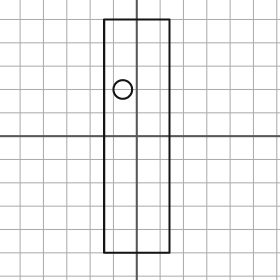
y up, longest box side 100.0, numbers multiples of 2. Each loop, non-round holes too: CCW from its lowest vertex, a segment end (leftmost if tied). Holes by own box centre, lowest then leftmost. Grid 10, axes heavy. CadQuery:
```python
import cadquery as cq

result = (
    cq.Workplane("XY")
    .moveTo(-14.0, -50.0)
    .lineTo(14.0, -50.0)
    .lineTo(14.0, 50.0)
    .lineTo(-14.0, 50.0)
    .close()
    .moveTo(-6.0, 20.0)
    .circle(4.0)
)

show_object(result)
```